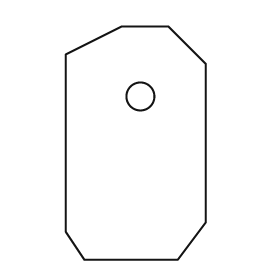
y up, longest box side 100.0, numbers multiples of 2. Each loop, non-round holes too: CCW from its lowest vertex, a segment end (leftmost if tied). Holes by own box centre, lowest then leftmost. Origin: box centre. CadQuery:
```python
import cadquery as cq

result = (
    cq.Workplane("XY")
    .moveTo(-22.0, -50.0)
    .lineTo(18.0, -50.0)
    .lineTo(30.0, -34.0)
    .lineTo(30.0, 34.0)
    .lineTo(14.0, 50.0)
    .lineTo(-6.0, 50.0)
    .lineTo(-30.0, 38.0)
    .lineTo(-30.0, -38.0)
    .close()
    .moveTo(2.0, 20.0)
    .circle(6.0)
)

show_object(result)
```